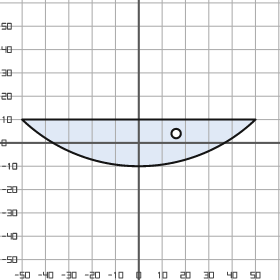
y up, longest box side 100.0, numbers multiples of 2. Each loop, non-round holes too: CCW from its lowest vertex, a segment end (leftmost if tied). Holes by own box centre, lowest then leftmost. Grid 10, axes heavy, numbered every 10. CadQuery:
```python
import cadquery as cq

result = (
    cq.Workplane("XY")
    .moveTo(-50.0, 10.0)
    .threePointArc((0.0, -10.0), (50.0, 10.0))
    .close()
    .moveTo(16.0, 4.0)
    .circle(2.0)
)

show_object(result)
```